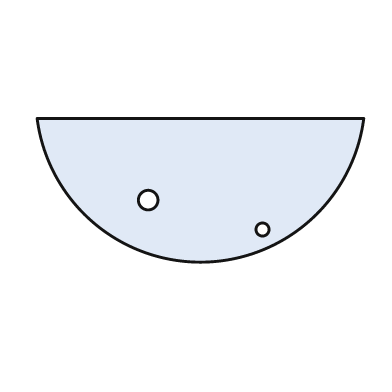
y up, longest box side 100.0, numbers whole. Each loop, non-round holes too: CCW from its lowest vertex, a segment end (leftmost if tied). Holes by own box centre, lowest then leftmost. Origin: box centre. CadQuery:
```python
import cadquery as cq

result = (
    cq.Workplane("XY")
    .moveTo(-50.0, 22.0)
    .threePointArc((0.0, -22.0), (50.0, 22.0))
    .close()
    .moveTo(19.0, -12.0)
    .circle(2.0)
    .moveTo(-16.0, -3.0)
    .circle(3.0)
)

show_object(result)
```